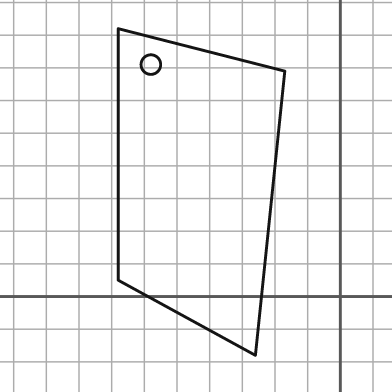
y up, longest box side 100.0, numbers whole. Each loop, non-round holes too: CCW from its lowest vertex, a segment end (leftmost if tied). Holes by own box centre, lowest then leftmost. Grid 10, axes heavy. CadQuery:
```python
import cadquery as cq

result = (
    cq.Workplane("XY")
    .moveTo(-26.0, -18.0)
    .lineTo(-17.0, 69.0)
    .lineTo(-68.0, 82.0)
    .lineTo(-68.0, 5.0)
    .close()
    .moveTo(-58.0, 71.0)
    .circle(3.0)
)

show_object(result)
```